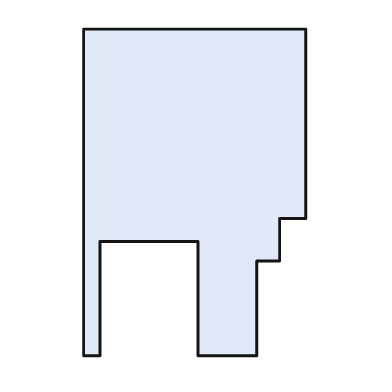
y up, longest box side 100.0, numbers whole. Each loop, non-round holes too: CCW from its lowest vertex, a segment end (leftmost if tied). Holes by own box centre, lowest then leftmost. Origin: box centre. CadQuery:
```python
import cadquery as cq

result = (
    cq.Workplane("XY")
    .moveTo(-34.0, -50.0)
    .lineTo(-29.0, -50.0)
    .lineTo(-29.0, -15.0)
    .lineTo(1.0, -15.0)
    .lineTo(1.0, -50.0)
    .lineTo(19.0, -50.0)
    .lineTo(19.0, -21.0)
    .lineTo(26.0, -21.0)
    .lineTo(26.0, -8.0)
    .lineTo(34.0, -8.0)
    .lineTo(34.0, 50.0)
    .lineTo(-34.0, 50.0)
    .close()
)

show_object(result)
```